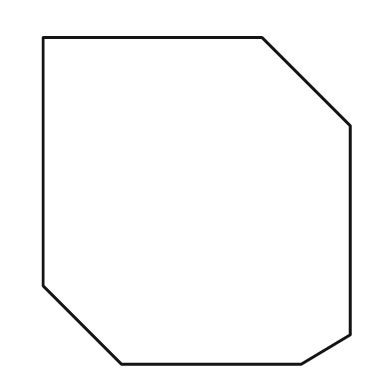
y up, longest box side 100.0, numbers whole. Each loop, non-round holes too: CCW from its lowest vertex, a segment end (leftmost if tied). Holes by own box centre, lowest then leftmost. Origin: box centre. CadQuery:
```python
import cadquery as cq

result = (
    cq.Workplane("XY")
    .moveTo(-23.0, -50.0)
    .lineTo(32.0, -50.0)
    .lineTo(47.0, -41.0)
    .lineTo(47.0, 23.0)
    .lineTo(20.0, 50.0)
    .lineTo(-47.0, 50.0)
    .lineTo(-47.0, -26.0)
    .close()
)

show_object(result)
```